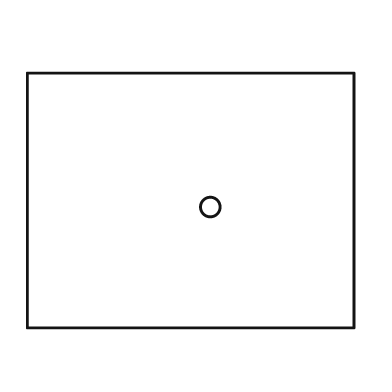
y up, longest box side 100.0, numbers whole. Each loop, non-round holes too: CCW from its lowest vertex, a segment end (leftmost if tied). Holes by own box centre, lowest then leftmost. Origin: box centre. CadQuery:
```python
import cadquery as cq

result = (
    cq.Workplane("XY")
    .moveTo(-50.0, -39.0)
    .lineTo(50.0, -39.0)
    .lineTo(50.0, 39.0)
    .lineTo(-50.0, 39.0)
    .close()
    .moveTo(6.0, -2.0)
    .circle(3.0)
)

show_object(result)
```